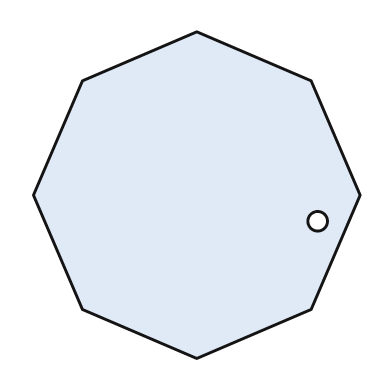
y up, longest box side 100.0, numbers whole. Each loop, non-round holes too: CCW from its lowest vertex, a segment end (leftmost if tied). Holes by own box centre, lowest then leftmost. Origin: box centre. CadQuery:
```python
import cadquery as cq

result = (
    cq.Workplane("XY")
    .moveTo(0.0, -50.0)
    .lineTo(35.0, -35.0)
    .lineTo(50.0, 0.0)
    .lineTo(35.0, 35.0)
    .lineTo(0.0, 50.0)
    .lineTo(-35.0, 35.0)
    .lineTo(-50.0, 0.0)
    .lineTo(-35.0, -35.0)
    .close()
    .moveTo(37.0, -8.0)
    .circle(3.0)
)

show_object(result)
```